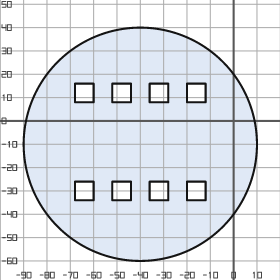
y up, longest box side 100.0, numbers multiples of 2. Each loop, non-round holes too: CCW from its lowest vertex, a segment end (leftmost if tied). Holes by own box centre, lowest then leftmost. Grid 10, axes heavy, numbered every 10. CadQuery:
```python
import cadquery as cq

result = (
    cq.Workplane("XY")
    .moveTo(-40.0, -10.0)
    .circle(50.0)
    .moveTo(-68.0, -34.0)
    .lineTo(-60.0, -34.0)
    .lineTo(-60.0, -26.0)
    .lineTo(-68.0, -26.0)
    .close()
    .moveTo(-52.0, -34.0)
    .lineTo(-44.0, -34.0)
    .lineTo(-44.0, -26.0)
    .lineTo(-52.0, -26.0)
    .close()
    .moveTo(-36.0, -34.0)
    .lineTo(-28.0, -34.0)
    .lineTo(-28.0, -26.0)
    .lineTo(-36.0, -26.0)
    .close()
    .moveTo(-20.0, -34.0)
    .lineTo(-12.0, -34.0)
    .lineTo(-12.0, -26.0)
    .lineTo(-20.0, -26.0)
    .close()
    .moveTo(-68.0, 8.0)
    .lineTo(-60.0, 8.0)
    .lineTo(-60.0, 16.0)
    .lineTo(-68.0, 16.0)
    .close()
    .moveTo(-52.0, 8.0)
    .lineTo(-44.0, 8.0)
    .lineTo(-44.0, 16.0)
    .lineTo(-52.0, 16.0)
    .close()
    .moveTo(-36.0, 8.0)
    .lineTo(-28.0, 8.0)
    .lineTo(-28.0, 16.0)
    .lineTo(-36.0, 16.0)
    .close()
    .moveTo(-20.0, 8.0)
    .lineTo(-12.0, 8.0)
    .lineTo(-12.0, 16.0)
    .lineTo(-20.0, 16.0)
    .close()
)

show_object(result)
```